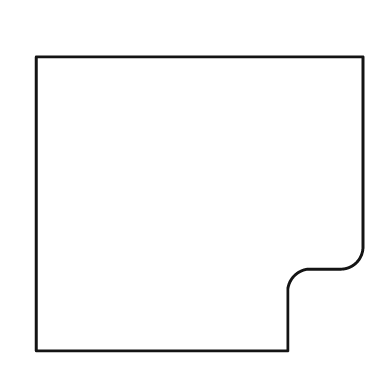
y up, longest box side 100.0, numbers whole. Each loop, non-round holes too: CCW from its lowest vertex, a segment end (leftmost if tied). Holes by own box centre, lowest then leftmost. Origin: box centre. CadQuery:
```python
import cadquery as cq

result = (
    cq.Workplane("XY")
    .moveTo(-50.0, -45.0)
    .lineTo(27.0, -45.0)
    .lineTo(27.0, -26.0)
    .threePointArc((29.0, -22.0), (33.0, -20.0))
    .lineTo(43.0, -20.0)
    .threePointArc((48.0, -18.0), (50.0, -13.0))
    .lineTo(50.0, 45.0)
    .lineTo(-50.0, 45.0)
    .close()
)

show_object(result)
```